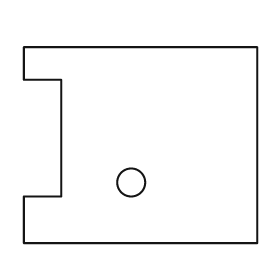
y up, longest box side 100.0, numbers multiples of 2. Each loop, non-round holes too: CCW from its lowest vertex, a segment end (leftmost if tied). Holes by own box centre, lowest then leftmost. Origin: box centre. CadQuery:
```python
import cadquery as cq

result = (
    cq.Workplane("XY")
    .moveTo(-50.0, -42.0)
    .lineTo(50.0, -42.0)
    .lineTo(50.0, 42.0)
    .lineTo(-50.0, 42.0)
    .lineTo(-50.0, 28.0)
    .lineTo(-34.0, 28.0)
    .lineTo(-34.0, -22.0)
    .lineTo(-50.0, -22.0)
    .close()
    .moveTo(-4.0, -16.0)
    .circle(6.0)
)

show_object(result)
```